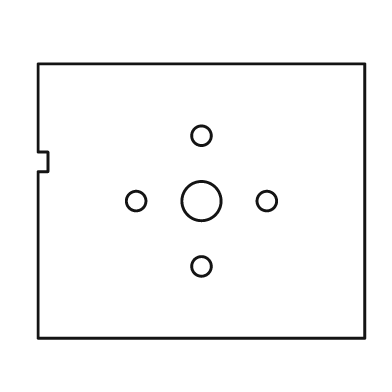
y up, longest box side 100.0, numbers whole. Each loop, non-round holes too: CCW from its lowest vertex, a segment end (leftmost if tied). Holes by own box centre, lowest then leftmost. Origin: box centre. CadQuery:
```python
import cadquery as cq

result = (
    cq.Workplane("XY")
    .moveTo(-50.0, -42.0)
    .lineTo(50.0, -42.0)
    .lineTo(50.0, 42.0)
    .lineTo(-50.0, 42.0)
    .lineTo(-50.0, 15.0)
    .lineTo(-47.0, 15.0)
    .lineTo(-47.0, 9.0)
    .lineTo(-50.0, 9.0)
    .close()
    .moveTo(0.0, -20.0)
    .circle(3.0)
    .moveTo(-20.0, 0.0)
    .circle(3.0)
    .moveTo(0.0, 0.0)
    .circle(6.0)
    .moveTo(20.0, 0.0)
    .circle(3.0)
    .moveTo(0.0, 20.0)
    .circle(3.0)
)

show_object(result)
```